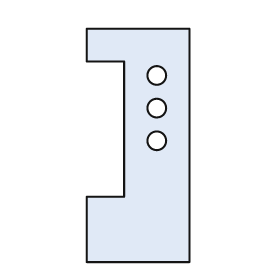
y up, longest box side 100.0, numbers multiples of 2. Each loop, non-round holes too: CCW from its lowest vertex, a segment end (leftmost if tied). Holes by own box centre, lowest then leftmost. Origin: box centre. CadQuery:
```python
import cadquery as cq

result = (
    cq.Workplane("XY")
    .moveTo(-22.0, -50.0)
    .lineTo(22.0, -50.0)
    .lineTo(22.0, 50.0)
    .lineTo(-22.0, 50.0)
    .lineTo(-22.0, 36.0)
    .lineTo(-6.0, 36.0)
    .lineTo(-6.0, -22.0)
    .lineTo(-22.0, -22.0)
    .close()
    .moveTo(8.0, 2.0)
    .circle(4.0)
    .moveTo(8.0, 16.0)
    .circle(4.0)
    .moveTo(8.0, 30.0)
    .circle(4.0)
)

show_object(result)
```